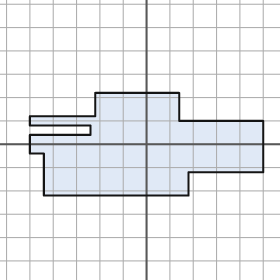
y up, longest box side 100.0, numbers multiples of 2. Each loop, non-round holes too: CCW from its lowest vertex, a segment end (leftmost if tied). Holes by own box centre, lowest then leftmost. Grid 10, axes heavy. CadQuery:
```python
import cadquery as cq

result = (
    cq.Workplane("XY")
    .moveTo(-44.0, -22.0)
    .lineTo(18.0, -22.0)
    .lineTo(18.0, -12.0)
    .lineTo(50.0, -12.0)
    .lineTo(50.0, 10.0)
    .lineTo(14.0, 10.0)
    .lineTo(14.0, 22.0)
    .lineTo(-22.0, 22.0)
    .lineTo(-22.0, 12.0)
    .lineTo(-50.0, 12.0)
    .lineTo(-50.0, 8.0)
    .lineTo(-24.0, 8.0)
    .lineTo(-24.0, 4.0)
    .lineTo(-50.0, 4.0)
    .lineTo(-50.0, -4.0)
    .lineTo(-44.0, -4.0)
    .close()
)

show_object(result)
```